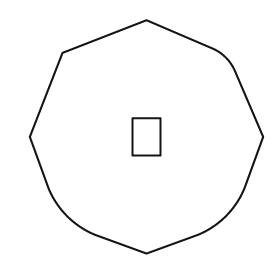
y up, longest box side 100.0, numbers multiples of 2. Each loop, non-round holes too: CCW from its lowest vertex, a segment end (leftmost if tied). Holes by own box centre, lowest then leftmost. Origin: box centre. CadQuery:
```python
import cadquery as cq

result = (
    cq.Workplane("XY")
    .moveTo(0.0, -50.0)
    .lineTo(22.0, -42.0)
    .threePointArc((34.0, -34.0), (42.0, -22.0))
    .lineTo(50.0, 0.0)
    .lineTo(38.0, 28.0)
    .threePointArc((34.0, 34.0), (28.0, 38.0))
    .lineTo(0.0, 50.0)
    .lineTo(-36.0, 36.0)
    .lineTo(-50.0, 0.0)
    .lineTo(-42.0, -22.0)
    .threePointArc((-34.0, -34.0), (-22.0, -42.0))
    .close()
    .moveTo(-6.0, -8.0)
    .lineTo(6.0, -8.0)
    .lineTo(6.0, 8.0)
    .lineTo(-6.0, 8.0)
    .close()
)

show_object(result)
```